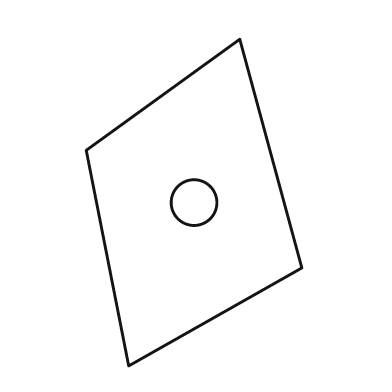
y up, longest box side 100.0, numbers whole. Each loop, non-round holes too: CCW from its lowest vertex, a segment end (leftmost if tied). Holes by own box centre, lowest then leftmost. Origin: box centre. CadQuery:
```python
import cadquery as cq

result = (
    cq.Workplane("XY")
    .moveTo(-20.0, -50.0)
    .lineTo(33.0, -20.0)
    .lineTo(14.0, 50.0)
    .lineTo(-33.0, 16.0)
    .close()
    .moveTo(0.0, 0.0)
    .circle(7.0)
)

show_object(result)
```